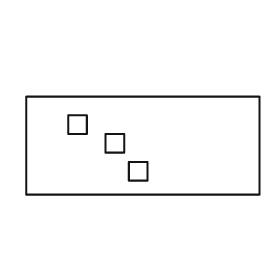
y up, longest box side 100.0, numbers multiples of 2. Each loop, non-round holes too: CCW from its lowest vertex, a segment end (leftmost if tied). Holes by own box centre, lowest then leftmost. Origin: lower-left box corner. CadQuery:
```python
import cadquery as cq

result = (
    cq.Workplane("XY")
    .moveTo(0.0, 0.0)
    .lineTo(100.0, 0.0)
    .lineTo(100.0, 42.0)
    .lineTo(0.0, 42.0)
    .close()
    .moveTo(44.0, 6.0)
    .lineTo(52.0, 6.0)
    .lineTo(52.0, 14.0)
    .lineTo(44.0, 14.0)
    .close()
    .moveTo(34.0, 18.0)
    .lineTo(42.0, 18.0)
    .lineTo(42.0, 26.0)
    .lineTo(34.0, 26.0)
    .close()
    .moveTo(18.0, 26.0)
    .lineTo(26.0, 26.0)
    .lineTo(26.0, 34.0)
    .lineTo(18.0, 34.0)
    .close()
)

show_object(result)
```